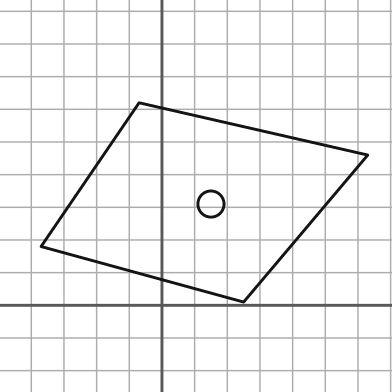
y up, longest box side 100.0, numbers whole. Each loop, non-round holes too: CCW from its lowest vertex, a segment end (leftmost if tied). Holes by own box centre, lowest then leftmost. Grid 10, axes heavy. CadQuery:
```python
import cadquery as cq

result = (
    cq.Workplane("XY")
    .moveTo(25.0, 1.0)
    .lineTo(63.0, 46.0)
    .lineTo(-7.0, 62.0)
    .lineTo(-37.0, 18.0)
    .close()
    .moveTo(15.0, 31.0)
    .circle(4.0)
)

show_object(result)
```